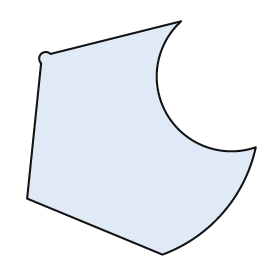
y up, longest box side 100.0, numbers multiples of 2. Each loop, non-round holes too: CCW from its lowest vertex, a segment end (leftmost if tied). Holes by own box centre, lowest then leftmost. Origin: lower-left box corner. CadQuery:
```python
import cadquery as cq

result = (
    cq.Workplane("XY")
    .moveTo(58.0, 0.0)
    .threePointArc((84.0, 18.0), (98.0, 46.0))
    .threePointArc((60.0, 60.0), (66.0, 100.0))
    .lineTo(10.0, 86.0)
    .threePointArc((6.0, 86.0), (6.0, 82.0))
    .lineTo(0.0, 24.0)
    .close()
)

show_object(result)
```